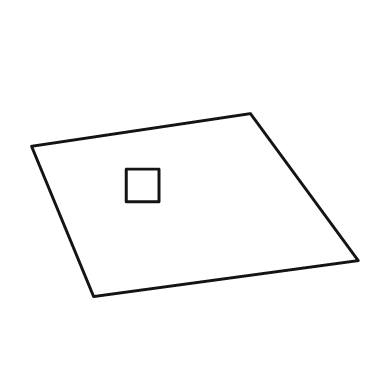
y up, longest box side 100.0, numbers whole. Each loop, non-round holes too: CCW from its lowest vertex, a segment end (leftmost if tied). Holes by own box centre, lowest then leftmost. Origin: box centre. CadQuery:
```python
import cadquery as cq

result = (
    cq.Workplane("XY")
    .moveTo(-31.0, -28.0)
    .lineTo(50.0, -17.0)
    .lineTo(17.0, 28.0)
    .lineTo(-50.0, 18.0)
    .close()
    .moveTo(-21.0, 1.0)
    .lineTo(-11.0, 1.0)
    .lineTo(-11.0, 11.0)
    .lineTo(-21.0, 11.0)
    .close()
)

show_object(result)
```